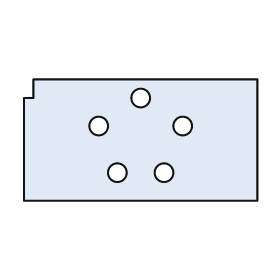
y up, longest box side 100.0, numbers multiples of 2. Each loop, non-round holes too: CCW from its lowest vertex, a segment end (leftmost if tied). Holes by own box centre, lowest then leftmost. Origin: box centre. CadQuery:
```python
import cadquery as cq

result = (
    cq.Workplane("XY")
    .moveTo(-50.0, -26.0)
    .lineTo(50.0, -26.0)
    .lineTo(50.0, 26.0)
    .lineTo(-46.0, 26.0)
    .lineTo(-46.0, 18.0)
    .lineTo(-50.0, 18.0)
    .close()
    .moveTo(-10.0, -14.0)
    .circle(4.0)
    .moveTo(10.0, -14.0)
    .circle(4.0)
    .moveTo(-18.0, 6.0)
    .circle(4.0)
    .moveTo(18.0, 6.0)
    .circle(4.0)
    .moveTo(0.0, 18.0)
    .circle(4.0)
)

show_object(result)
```